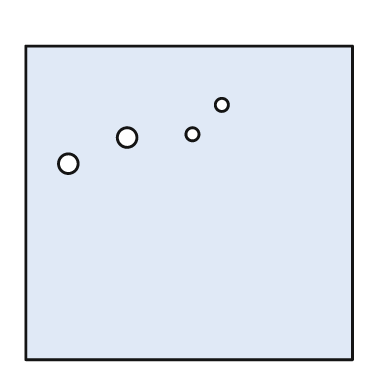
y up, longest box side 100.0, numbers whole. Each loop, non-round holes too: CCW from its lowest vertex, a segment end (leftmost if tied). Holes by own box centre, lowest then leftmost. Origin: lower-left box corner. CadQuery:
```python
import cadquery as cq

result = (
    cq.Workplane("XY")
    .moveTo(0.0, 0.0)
    .lineTo(100.0, 0.0)
    .lineTo(100.0, 96.0)
    .lineTo(0.0, 96.0)
    .close()
    .moveTo(13.0, 60.0)
    .circle(3.0)
    .moveTo(31.0, 68.0)
    .circle(3.0)
    .moveTo(51.0, 69.0)
    .circle(2.0)
    .moveTo(60.0, 78.0)
    .circle(2.0)
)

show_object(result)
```